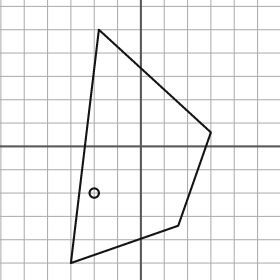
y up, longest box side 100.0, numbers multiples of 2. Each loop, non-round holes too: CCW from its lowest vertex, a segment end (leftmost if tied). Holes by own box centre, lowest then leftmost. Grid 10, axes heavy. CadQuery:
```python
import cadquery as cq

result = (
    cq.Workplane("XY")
    .moveTo(-30.0, -50.0)
    .lineTo(16.0, -34.0)
    .lineTo(30.0, 6.0)
    .lineTo(-18.0, 50.0)
    .close()
    .moveTo(-20.0, -20.0)
    .circle(2.0)
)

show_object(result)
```